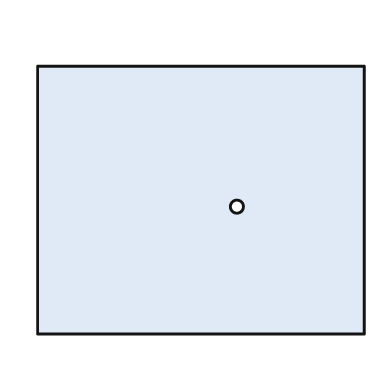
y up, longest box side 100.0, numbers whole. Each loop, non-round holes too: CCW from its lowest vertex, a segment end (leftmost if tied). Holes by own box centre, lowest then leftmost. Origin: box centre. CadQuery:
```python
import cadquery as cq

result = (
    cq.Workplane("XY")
    .moveTo(-50.0, -41.0)
    .lineTo(50.0, -41.0)
    .lineTo(50.0, 41.0)
    .lineTo(-50.0, 41.0)
    .close()
    .moveTo(11.0, -2.0)
    .circle(2.0)
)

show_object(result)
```